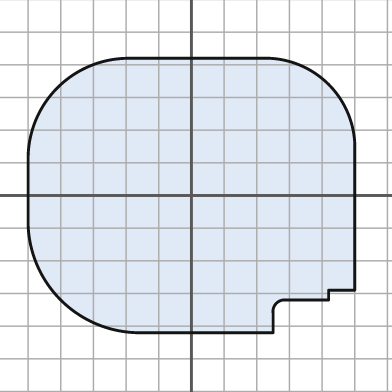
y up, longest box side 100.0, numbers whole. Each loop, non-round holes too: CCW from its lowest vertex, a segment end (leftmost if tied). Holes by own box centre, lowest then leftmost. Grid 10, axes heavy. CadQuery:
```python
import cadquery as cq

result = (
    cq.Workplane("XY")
    .moveTo(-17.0, -42.0)
    .lineTo(25.0, -42.0)
    .lineTo(25.0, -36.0)
    .threePointArc((26.0, -33.0), (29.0, -32.0))
    .lineTo(42.0, -32.0)
    .lineTo(42.0, -29.0)
    .lineTo(50.0, -29.0)
    .lineTo(50.0, 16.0)
    .threePointArc((42.0, 34.0), (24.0, 42.0))
    .lineTo(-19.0, 42.0)
    .threePointArc((-41.0, 33.0), (-50.0, 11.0))
    .lineTo(-50.0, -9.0)
    .threePointArc((-40.0, -32.0), (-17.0, -42.0))
    .close()
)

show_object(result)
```